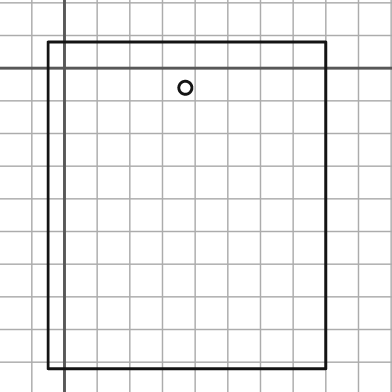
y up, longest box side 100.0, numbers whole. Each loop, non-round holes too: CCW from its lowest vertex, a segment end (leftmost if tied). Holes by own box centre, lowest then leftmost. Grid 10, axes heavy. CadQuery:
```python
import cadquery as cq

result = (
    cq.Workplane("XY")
    .moveTo(-5.0, -92.0)
    .lineTo(80.0, -92.0)
    .lineTo(80.0, 8.0)
    .lineTo(-5.0, 8.0)
    .close()
    .moveTo(37.0, -6.0)
    .circle(2.0)
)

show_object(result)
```